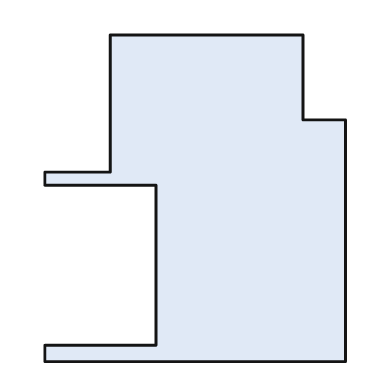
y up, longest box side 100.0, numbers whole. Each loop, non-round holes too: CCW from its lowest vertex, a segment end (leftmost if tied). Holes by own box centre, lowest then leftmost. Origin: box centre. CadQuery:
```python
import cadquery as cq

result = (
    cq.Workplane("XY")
    .moveTo(-46.0, -50.0)
    .lineTo(46.0, -50.0)
    .lineTo(46.0, 24.0)
    .lineTo(33.0, 24.0)
    .lineTo(33.0, 50.0)
    .lineTo(-26.0, 50.0)
    .lineTo(-26.0, 8.0)
    .lineTo(-46.0, 8.0)
    .lineTo(-46.0, 4.0)
    .lineTo(-12.0, 4.0)
    .lineTo(-12.0, -45.0)
    .lineTo(-46.0, -45.0)
    .close()
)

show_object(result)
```